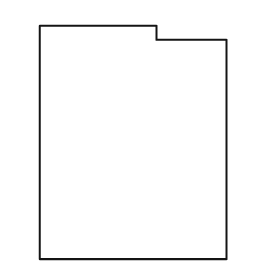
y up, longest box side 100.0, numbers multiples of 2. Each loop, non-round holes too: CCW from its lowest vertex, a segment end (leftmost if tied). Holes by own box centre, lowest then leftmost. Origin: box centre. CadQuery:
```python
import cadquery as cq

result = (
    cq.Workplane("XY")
    .moveTo(-40.0, -50.0)
    .lineTo(40.0, -50.0)
    .lineTo(40.0, 44.0)
    .lineTo(10.0, 44.0)
    .lineTo(10.0, 50.0)
    .lineTo(-40.0, 50.0)
    .close()
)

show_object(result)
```